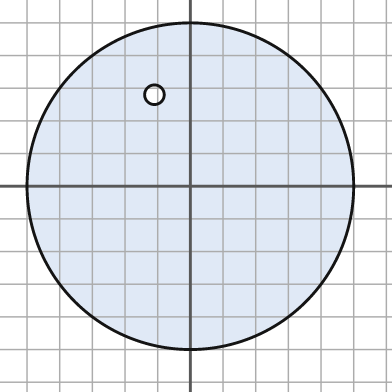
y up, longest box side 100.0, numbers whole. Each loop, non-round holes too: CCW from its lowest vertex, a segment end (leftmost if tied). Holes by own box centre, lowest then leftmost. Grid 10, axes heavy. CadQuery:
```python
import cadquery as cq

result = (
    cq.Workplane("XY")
    .moveTo(0.0, 0.0)
    .circle(50.0)
    .moveTo(-11.0, 28.0)
    .circle(3.0)
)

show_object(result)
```